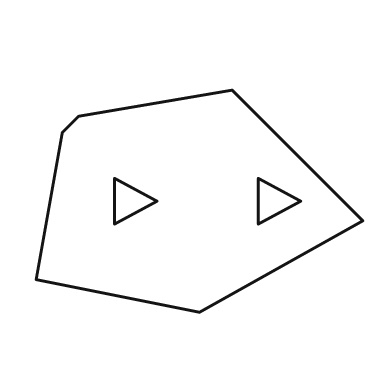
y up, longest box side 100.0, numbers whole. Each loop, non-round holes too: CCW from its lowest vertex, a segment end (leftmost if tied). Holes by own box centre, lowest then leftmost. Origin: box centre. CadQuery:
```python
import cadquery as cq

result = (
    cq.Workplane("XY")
    .moveTo(0.0, -34.0)
    .lineTo(50.0, -6.0)
    .lineTo(10.0, 34.0)
    .lineTo(-37.0, 26.0)
    .lineTo(-42.0, 21.0)
    .lineTo(-50.0, -24.0)
    .close()
    .moveTo(-26.0, -7.0)
    .lineTo(-13.0, 0.0)
    .lineTo(-26.0, 7.0)
    .close()
    .moveTo(18.0, -7.0)
    .lineTo(31.0, 0.0)
    .lineTo(18.0, 7.0)
    .close()
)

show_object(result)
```